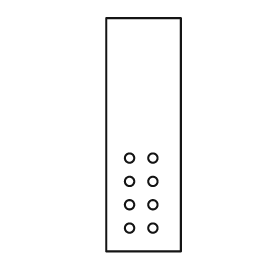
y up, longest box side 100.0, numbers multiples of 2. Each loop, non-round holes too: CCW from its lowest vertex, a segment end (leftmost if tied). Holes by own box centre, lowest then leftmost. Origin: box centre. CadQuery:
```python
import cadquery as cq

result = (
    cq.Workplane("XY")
    .moveTo(-16.0, -50.0)
    .lineTo(16.0, -50.0)
    .lineTo(16.0, 50.0)
    .lineTo(-16.0, 50.0)
    .close()
    .moveTo(-6.0, -40.0)
    .circle(2.0)
    .moveTo(4.0, -40.0)
    .circle(2.0)
    .moveTo(-6.0, -30.0)
    .circle(2.0)
    .moveTo(4.0, -30.0)
    .circle(2.0)
    .moveTo(-6.0, -20.0)
    .circle(2.0)
    .moveTo(4.0, -20.0)
    .circle(2.0)
    .moveTo(-6.0, -10.0)
    .circle(2.0)
    .moveTo(4.0, -10.0)
    .circle(2.0)
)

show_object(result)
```